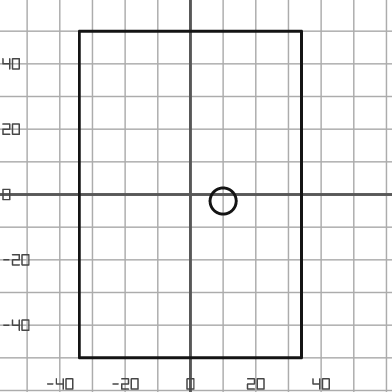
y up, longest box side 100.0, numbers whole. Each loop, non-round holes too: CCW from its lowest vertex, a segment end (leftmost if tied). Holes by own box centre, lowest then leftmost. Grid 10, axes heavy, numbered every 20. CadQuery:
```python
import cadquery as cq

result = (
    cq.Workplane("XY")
    .moveTo(-34.0, -50.0)
    .lineTo(34.0, -50.0)
    .lineTo(34.0, 50.0)
    .lineTo(-34.0, 50.0)
    .close()
    .moveTo(10.0, -2.0)
    .circle(4.0)
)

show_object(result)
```